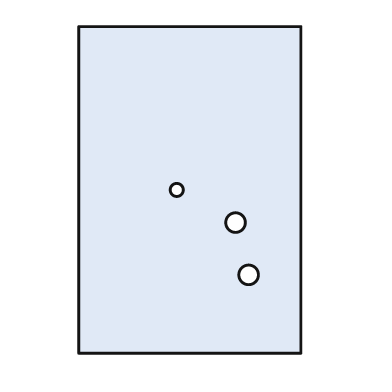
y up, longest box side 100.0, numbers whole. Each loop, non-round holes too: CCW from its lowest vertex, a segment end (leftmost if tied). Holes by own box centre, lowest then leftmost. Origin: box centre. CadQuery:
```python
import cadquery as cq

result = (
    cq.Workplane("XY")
    .moveTo(-34.0, -50.0)
    .lineTo(34.0, -50.0)
    .lineTo(34.0, 50.0)
    .lineTo(-34.0, 50.0)
    .close()
    .moveTo(18.0, -26.0)
    .circle(3.0)
    .moveTo(14.0, -10.0)
    .circle(3.0)
    .moveTo(-4.0, 0.0)
    .circle(2.0)
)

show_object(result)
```